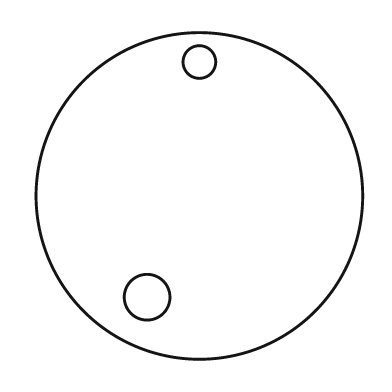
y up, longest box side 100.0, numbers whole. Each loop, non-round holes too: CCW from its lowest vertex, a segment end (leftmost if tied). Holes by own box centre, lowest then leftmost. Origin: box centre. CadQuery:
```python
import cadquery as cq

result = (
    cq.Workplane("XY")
    .moveTo(0.0, 0.0)
    .circle(50.0)
    .moveTo(-16.0, -31.0)
    .circle(7.0)
    .moveTo(0.0, 41.0)
    .circle(5.0)
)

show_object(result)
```